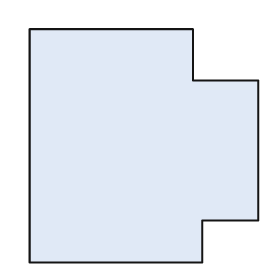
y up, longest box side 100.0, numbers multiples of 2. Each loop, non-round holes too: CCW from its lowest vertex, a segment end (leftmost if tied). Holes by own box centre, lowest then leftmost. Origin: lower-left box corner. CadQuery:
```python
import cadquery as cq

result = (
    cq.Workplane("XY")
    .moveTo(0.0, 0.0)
    .lineTo(74.0, 0.0)
    .lineTo(74.0, 18.0)
    .lineTo(98.0, 18.0)
    .lineTo(98.0, 78.0)
    .lineTo(70.0, 78.0)
    .lineTo(70.0, 100.0)
    .lineTo(0.0, 100.0)
    .close()
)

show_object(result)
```